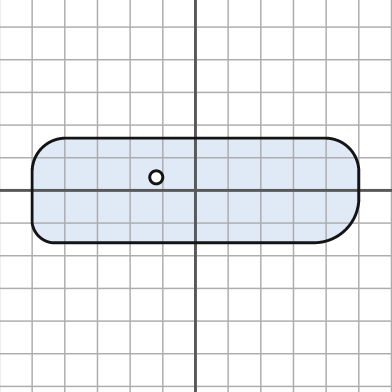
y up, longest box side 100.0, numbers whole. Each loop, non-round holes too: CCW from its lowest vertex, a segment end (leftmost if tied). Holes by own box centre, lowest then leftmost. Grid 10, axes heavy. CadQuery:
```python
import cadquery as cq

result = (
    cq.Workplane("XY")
    .moveTo(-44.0, -16.0)
    .lineTo(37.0, -16.0)
    .threePointArc((46.0, -12.0), (50.0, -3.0))
    .lineTo(50.0, 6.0)
    .threePointArc((47.0, 13.0), (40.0, 16.0))
    .lineTo(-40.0, 16.0)
    .threePointArc((-47.0, 13.0), (-50.0, 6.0))
    .lineTo(-50.0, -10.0)
    .threePointArc((-48.0, -14.0), (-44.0, -16.0))
    .close()
    .moveTo(-12.0, 4.0)
    .circle(2.0)
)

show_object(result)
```